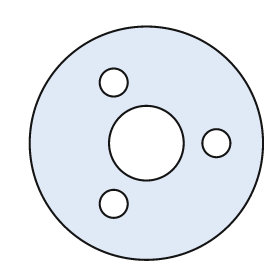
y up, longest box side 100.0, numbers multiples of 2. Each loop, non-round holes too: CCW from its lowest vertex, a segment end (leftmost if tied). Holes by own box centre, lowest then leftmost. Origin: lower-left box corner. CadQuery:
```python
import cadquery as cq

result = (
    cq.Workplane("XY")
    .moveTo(50.0, 50.0)
    .circle(50.0)
    .moveTo(36.0, 24.0)
    .circle(6.0)
    .moveTo(50.0, 50.0)
    .circle(16.0)
    .moveTo(80.0, 50.0)
    .circle(6.0)
    .moveTo(36.0, 76.0)
    .circle(6.0)
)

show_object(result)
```